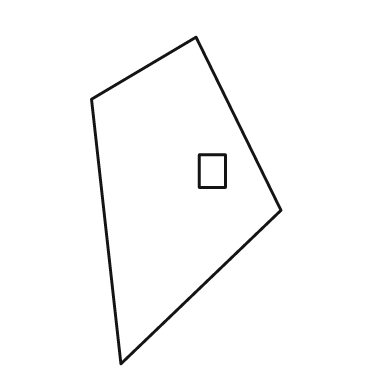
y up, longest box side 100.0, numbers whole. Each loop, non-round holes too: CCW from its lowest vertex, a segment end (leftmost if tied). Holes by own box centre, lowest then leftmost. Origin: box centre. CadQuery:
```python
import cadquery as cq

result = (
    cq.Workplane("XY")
    .moveTo(-20.0, -50.0)
    .lineTo(29.0, -3.0)
    .lineTo(3.0, 50.0)
    .lineTo(-29.0, 31.0)
    .close()
    .moveTo(4.0, 4.0)
    .lineTo(12.0, 4.0)
    .lineTo(12.0, 14.0)
    .lineTo(4.0, 14.0)
    .close()
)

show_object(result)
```